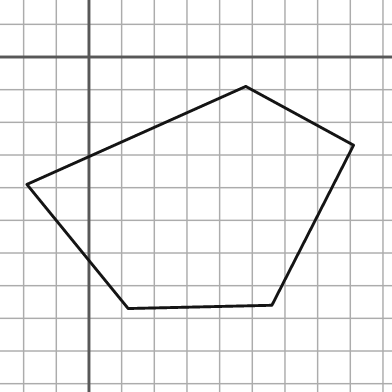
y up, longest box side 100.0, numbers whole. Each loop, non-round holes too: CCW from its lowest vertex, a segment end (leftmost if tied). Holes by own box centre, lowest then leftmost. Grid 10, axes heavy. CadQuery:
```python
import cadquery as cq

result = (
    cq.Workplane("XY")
    .moveTo(12.0, -77.0)
    .lineTo(56.0, -76.0)
    .lineTo(81.0, -27.0)
    .lineTo(48.0, -9.0)
    .lineTo(-19.0, -39.0)
    .close()
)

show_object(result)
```